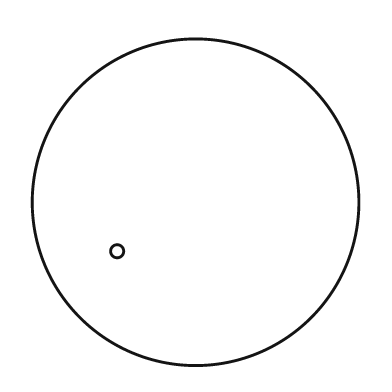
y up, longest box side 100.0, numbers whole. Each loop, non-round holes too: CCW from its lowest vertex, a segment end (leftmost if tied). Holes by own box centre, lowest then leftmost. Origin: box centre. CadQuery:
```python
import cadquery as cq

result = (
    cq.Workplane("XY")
    .moveTo(0.0, 0.0)
    .circle(50.0)
    .moveTo(-24.0, -15.0)
    .circle(2.0)
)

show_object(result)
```